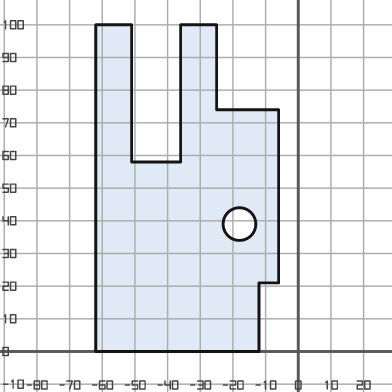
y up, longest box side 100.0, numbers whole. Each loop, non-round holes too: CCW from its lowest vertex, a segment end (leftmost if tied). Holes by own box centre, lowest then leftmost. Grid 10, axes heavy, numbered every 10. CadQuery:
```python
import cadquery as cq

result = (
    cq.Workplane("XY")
    .moveTo(-62.0, 0.0)
    .lineTo(-12.0, 0.0)
    .lineTo(-12.0, 21.0)
    .lineTo(-6.0, 21.0)
    .lineTo(-6.0, 74.0)
    .lineTo(-25.0, 74.0)
    .lineTo(-25.0, 100.0)
    .lineTo(-36.0, 100.0)
    .lineTo(-36.0, 58.0)
    .lineTo(-51.0, 58.0)
    .lineTo(-51.0, 100.0)
    .lineTo(-62.0, 100.0)
    .close()
    .moveTo(-18.0, 39.0)
    .circle(5.0)
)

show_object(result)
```